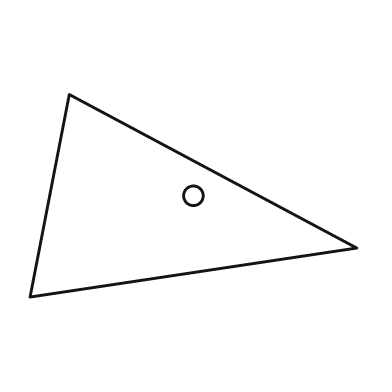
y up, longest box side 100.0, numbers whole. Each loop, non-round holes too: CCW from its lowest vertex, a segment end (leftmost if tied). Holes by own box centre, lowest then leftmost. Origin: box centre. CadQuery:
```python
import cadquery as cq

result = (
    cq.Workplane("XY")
    .moveTo(-50.0, -31.0)
    .lineTo(50.0, -16.0)
    .lineTo(-38.0, 31.0)
    .close()
    .moveTo(0.0, 0.0)
    .circle(3.0)
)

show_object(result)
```